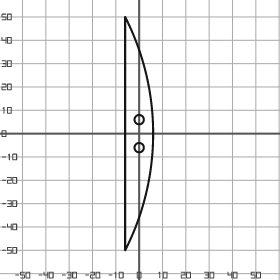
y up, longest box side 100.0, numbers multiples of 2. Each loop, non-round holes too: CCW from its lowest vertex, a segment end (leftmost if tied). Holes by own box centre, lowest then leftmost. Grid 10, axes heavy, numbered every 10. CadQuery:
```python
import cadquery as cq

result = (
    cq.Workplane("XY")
    .moveTo(-6.0, -50.0)
    .threePointArc((6.0, 0.0), (-6.0, 50.0))
    .close()
    .moveTo(0.0, -6.0)
    .circle(2.0)
    .moveTo(0.0, 6.0)
    .circle(2.0)
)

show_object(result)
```